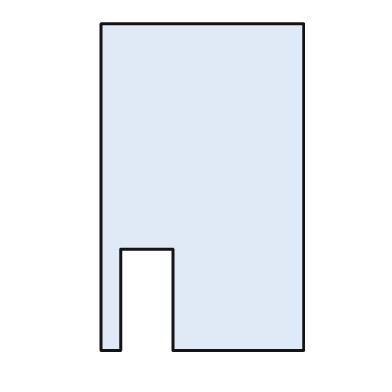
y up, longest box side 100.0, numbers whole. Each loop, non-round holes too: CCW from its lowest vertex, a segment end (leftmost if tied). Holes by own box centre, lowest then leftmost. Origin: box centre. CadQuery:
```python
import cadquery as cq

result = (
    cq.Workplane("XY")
    .moveTo(-31.0, -50.0)
    .lineTo(-25.0, -50.0)
    .lineTo(-25.0, -19.0)
    .lineTo(-9.0, -19.0)
    .lineTo(-9.0, -50.0)
    .lineTo(31.0, -50.0)
    .lineTo(31.0, 50.0)
    .lineTo(-31.0, 50.0)
    .close()
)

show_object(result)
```